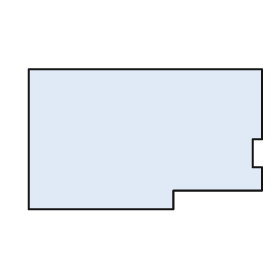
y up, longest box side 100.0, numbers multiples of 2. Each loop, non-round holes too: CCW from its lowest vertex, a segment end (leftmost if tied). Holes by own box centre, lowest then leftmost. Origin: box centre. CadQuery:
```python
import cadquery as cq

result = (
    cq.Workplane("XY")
    .moveTo(-50.0, -30.0)
    .lineTo(12.0, -30.0)
    .lineTo(12.0, -22.0)
    .lineTo(50.0, -22.0)
    .lineTo(50.0, -12.0)
    .lineTo(46.0, -12.0)
    .lineTo(46.0, 0.0)
    .lineTo(50.0, 0.0)
    .lineTo(50.0, 30.0)
    .lineTo(-50.0, 30.0)
    .close()
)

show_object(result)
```